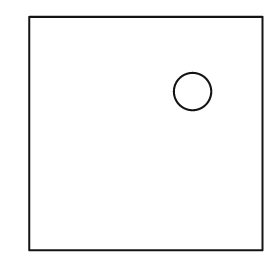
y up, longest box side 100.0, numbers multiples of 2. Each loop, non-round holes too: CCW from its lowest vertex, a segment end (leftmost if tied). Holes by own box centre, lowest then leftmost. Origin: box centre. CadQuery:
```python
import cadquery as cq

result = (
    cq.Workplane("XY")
    .moveTo(-50.0, -50.0)
    .lineTo(50.0, -50.0)
    .lineTo(50.0, 50.0)
    .lineTo(-50.0, 50.0)
    .close()
    .moveTo(20.0, 18.0)
    .circle(8.0)
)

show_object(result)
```